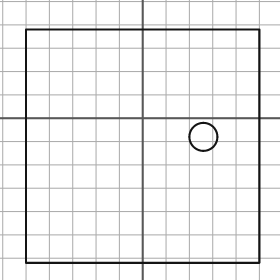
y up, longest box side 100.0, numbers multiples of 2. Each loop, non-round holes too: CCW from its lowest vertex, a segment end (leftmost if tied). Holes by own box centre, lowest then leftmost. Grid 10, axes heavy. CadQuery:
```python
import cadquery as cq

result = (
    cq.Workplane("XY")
    .moveTo(-50.0, -62.0)
    .lineTo(50.0, -62.0)
    .lineTo(50.0, 38.0)
    .lineTo(-50.0, 38.0)
    .close()
    .moveTo(26.0, -8.0)
    .circle(6.0)
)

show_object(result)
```